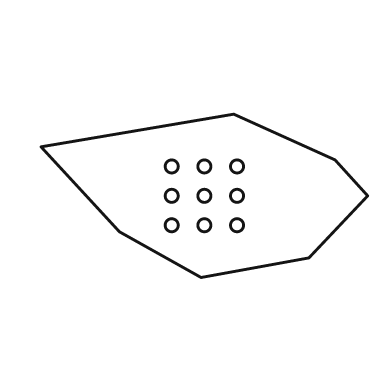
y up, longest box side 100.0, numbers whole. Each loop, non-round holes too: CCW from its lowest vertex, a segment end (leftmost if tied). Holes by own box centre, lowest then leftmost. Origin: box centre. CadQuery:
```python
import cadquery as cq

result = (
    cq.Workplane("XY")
    .moveTo(-1.0, -25.0)
    .lineTo(32.0, -19.0)
    .lineTo(50.0, 0.0)
    .lineTo(40.0, 11.0)
    .lineTo(9.0, 25.0)
    .lineTo(-50.0, 15.0)
    .lineTo(-26.0, -11.0)
    .close()
    .moveTo(-10.0, -9.0)
    .circle(2.0)
    .moveTo(0.0, -9.0)
    .circle(2.0)
    .moveTo(10.0, -9.0)
    .circle(2.0)
    .moveTo(-10.0, 0.0)
    .circle(2.0)
    .moveTo(0.0, 0.0)
    .circle(2.0)
    .moveTo(10.0, 0.0)
    .circle(2.0)
    .moveTo(-10.0, 9.0)
    .circle(2.0)
    .moveTo(0.0, 9.0)
    .circle(2.0)
    .moveTo(10.0, 9.0)
    .circle(2.0)
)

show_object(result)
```